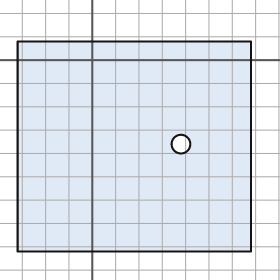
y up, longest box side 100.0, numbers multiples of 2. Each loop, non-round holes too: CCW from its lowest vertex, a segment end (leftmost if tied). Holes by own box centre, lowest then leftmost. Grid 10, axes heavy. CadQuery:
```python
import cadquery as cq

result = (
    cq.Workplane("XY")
    .moveTo(-32.0, -82.0)
    .lineTo(68.0, -82.0)
    .lineTo(68.0, 8.0)
    .lineTo(-32.0, 8.0)
    .close()
    .moveTo(38.0, -36.0)
    .circle(4.0)
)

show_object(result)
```